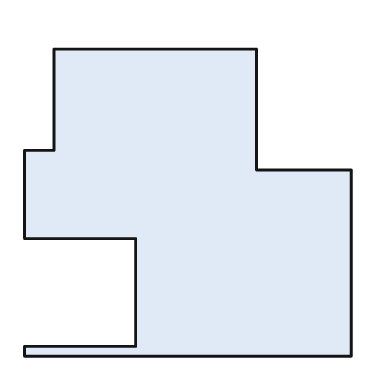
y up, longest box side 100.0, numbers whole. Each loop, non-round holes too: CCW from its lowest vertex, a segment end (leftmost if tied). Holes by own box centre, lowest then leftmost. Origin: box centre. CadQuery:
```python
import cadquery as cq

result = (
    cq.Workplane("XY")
    .moveTo(-50.0, -47.0)
    .lineTo(50.0, -47.0)
    .lineTo(50.0, 10.0)
    .lineTo(21.0, 10.0)
    .lineTo(21.0, 47.0)
    .lineTo(-41.0, 47.0)
    .lineTo(-41.0, 16.0)
    .lineTo(-50.0, 16.0)
    .lineTo(-50.0, -11.0)
    .lineTo(-16.0, -11.0)
    .lineTo(-16.0, -44.0)
    .lineTo(-50.0, -44.0)
    .close()
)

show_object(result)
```